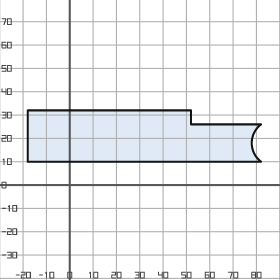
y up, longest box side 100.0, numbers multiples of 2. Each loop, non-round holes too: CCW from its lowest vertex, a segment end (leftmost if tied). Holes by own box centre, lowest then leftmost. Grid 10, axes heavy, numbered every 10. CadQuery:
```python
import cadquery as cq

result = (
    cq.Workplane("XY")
    .moveTo(-18.0, 10.0)
    .lineTo(82.0, 10.0)
    .threePointArc((78.0, 18.0), (82.0, 26.0))
    .lineTo(52.0, 26.0)
    .lineTo(52.0, 32.0)
    .lineTo(-18.0, 32.0)
    .close()
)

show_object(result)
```